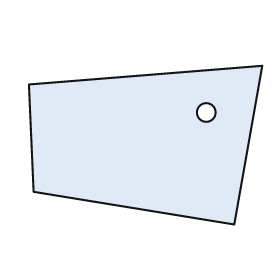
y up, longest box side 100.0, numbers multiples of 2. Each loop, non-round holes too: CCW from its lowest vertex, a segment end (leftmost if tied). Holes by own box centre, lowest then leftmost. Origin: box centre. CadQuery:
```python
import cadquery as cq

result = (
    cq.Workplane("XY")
    .moveTo(38.0, -34.0)
    .lineTo(50.0, 34.0)
    .lineTo(-50.0, 26.0)
    .lineTo(-48.0, -20.0)
    .close()
    .moveTo(26.0, 14.0)
    .circle(4.0)
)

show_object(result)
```